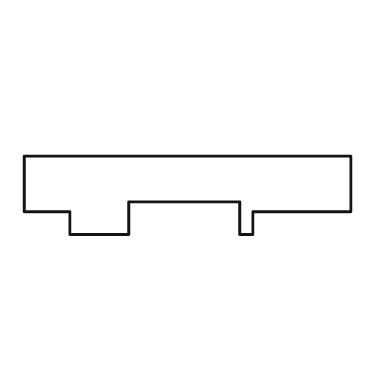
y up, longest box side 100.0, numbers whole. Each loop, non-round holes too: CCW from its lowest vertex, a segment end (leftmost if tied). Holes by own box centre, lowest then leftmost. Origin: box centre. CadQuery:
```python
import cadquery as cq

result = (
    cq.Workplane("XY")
    .moveTo(-36.0, -12.0)
    .lineTo(-18.0, -12.0)
    .lineTo(-18.0, -2.0)
    .lineTo(16.0, -2.0)
    .lineTo(16.0, -12.0)
    .lineTo(20.0, -12.0)
    .lineTo(20.0, -5.0)
    .lineTo(50.0, -5.0)
    .lineTo(50.0, 12.0)
    .lineTo(-50.0, 12.0)
    .lineTo(-50.0, -5.0)
    .lineTo(-36.0, -5.0)
    .close()
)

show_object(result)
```